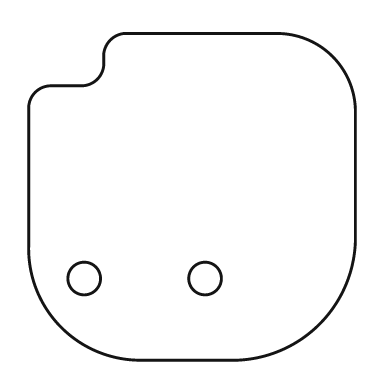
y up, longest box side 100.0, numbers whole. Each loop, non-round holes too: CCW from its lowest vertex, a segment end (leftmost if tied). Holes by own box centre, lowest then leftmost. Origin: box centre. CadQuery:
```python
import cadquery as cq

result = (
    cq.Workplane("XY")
    .moveTo(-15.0, -50.0)
    .lineTo(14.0, -50.0)
    .threePointArc((39.0, -39.0), (50.0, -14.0))
    .lineTo(50.0, 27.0)
    .threePointArc((43.0, 43.0), (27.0, 50.0))
    .lineTo(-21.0, 50.0)
    .threePointArc((-25.0, 48.0), (-27.0, 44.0))
    .lineTo(-27.0, 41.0)
    .threePointArc((-29.0, 36.0), (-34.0, 34.0))
    .lineTo(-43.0, 34.0)
    .threePointArc((-48.0, 32.0), (-50.0, 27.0))
    .lineTo(-50.0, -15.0)
    .threePointArc((-40.0, -40.0), (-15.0, -50.0))
    .close()
    .moveTo(-33.0, -25.0)
    .circle(5.0)
    .moveTo(4.0, -25.0)
    .circle(5.0)
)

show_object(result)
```